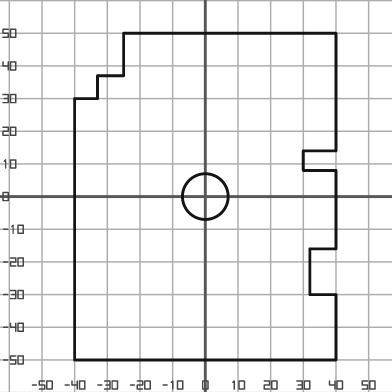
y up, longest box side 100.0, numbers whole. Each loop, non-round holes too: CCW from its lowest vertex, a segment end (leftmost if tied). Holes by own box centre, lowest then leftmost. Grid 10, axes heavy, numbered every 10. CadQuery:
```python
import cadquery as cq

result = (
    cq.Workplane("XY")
    .moveTo(-40.0, -50.0)
    .lineTo(40.0, -50.0)
    .lineTo(40.0, -30.0)
    .lineTo(32.0, -30.0)
    .lineTo(32.0, -16.0)
    .lineTo(40.0, -16.0)
    .lineTo(40.0, 8.0)
    .lineTo(30.0, 8.0)
    .lineTo(30.0, 14.0)
    .lineTo(40.0, 14.0)
    .lineTo(40.0, 50.0)
    .lineTo(-25.0, 50.0)
    .lineTo(-25.0, 37.0)
    .lineTo(-33.0, 37.0)
    .lineTo(-33.0, 30.0)
    .lineTo(-40.0, 30.0)
    .close()
    .moveTo(0.0, 0.0)
    .circle(7.0)
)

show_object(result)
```